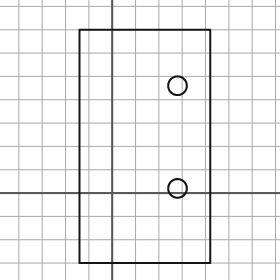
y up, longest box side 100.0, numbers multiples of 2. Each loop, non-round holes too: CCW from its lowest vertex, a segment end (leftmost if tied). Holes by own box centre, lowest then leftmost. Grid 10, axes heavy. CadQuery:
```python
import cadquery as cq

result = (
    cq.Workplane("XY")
    .moveTo(-14.0, -30.0)
    .lineTo(42.0, -30.0)
    .lineTo(42.0, 70.0)
    .lineTo(-14.0, 70.0)
    .close()
    .moveTo(28.0, 2.0)
    .circle(4.0)
    .moveTo(28.0, 46.0)
    .circle(4.0)
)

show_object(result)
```